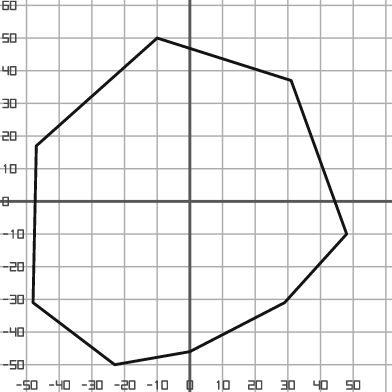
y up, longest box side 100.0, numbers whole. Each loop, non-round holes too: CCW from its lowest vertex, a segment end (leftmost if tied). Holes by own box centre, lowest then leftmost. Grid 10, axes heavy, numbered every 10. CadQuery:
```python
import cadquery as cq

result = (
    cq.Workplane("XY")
    .moveTo(-23.0, -50.0)
    .lineTo(0.0, -46.0)
    .lineTo(29.0, -31.0)
    .lineTo(48.0, -10.0)
    .lineTo(31.0, 37.0)
    .lineTo(-10.0, 50.0)
    .lineTo(-47.0, 17.0)
    .lineTo(-48.0, -31.0)
    .close()
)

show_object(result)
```